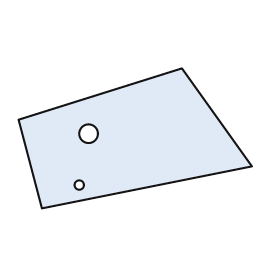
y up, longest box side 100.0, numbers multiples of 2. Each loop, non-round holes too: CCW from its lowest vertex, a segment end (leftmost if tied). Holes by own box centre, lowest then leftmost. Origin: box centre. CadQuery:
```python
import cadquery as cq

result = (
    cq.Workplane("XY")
    .moveTo(-40.0, -30.0)
    .lineTo(50.0, -12.0)
    .lineTo(20.0, 30.0)
    .lineTo(-50.0, 8.0)
    .close()
    .moveTo(-24.0, -20.0)
    .circle(2.0)
    .moveTo(-20.0, 2.0)
    .circle(4.0)
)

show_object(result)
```